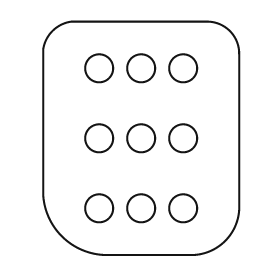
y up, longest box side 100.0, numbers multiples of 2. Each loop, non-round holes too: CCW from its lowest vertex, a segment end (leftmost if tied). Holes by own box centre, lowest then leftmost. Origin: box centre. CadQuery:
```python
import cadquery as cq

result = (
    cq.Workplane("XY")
    .moveTo(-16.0, -50.0)
    .lineTo(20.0, -50.0)
    .threePointArc((36.0, -44.0), (42.0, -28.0))
    .lineTo(42.0, 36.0)
    .threePointArc((38.0, 46.0), (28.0, 50.0))
    .lineTo(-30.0, 50.0)
    .threePointArc((-38.0, 46.0), (-42.0, 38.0))
    .lineTo(-42.0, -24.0)
    .threePointArc((-34.0, -42.0), (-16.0, -50.0))
    .close()
    .moveTo(-18.0, -30.0)
    .circle(6.0)
    .moveTo(0.0, -30.0)
    .circle(6.0)
    .moveTo(18.0, -30.0)
    .circle(6.0)
    .moveTo(-18.0, 0.0)
    .circle(6.0)
    .moveTo(0.0, 0.0)
    .circle(6.0)
    .moveTo(18.0, 0.0)
    .circle(6.0)
    .moveTo(-18.0, 30.0)
    .circle(6.0)
    .moveTo(0.0, 30.0)
    .circle(6.0)
    .moveTo(18.0, 30.0)
    .circle(6.0)
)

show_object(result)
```